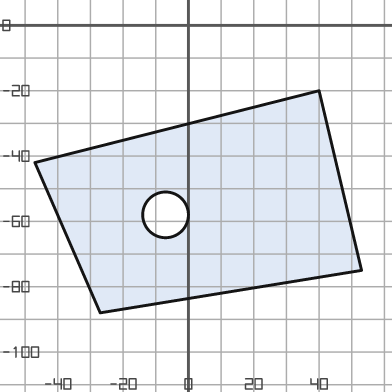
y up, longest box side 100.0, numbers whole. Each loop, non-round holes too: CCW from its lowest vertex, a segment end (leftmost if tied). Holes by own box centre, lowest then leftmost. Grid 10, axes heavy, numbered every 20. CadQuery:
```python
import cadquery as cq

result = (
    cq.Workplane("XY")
    .moveTo(-27.0, -88.0)
    .lineTo(53.0, -75.0)
    .lineTo(40.0, -20.0)
    .lineTo(-47.0, -42.0)
    .close()
    .moveTo(-7.0, -58.0)
    .circle(7.0)
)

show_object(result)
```